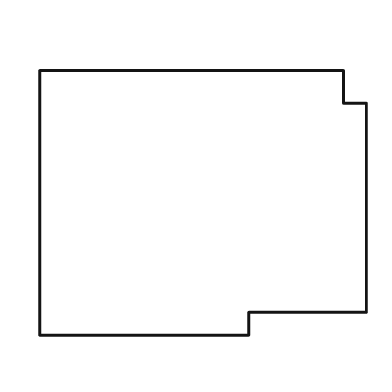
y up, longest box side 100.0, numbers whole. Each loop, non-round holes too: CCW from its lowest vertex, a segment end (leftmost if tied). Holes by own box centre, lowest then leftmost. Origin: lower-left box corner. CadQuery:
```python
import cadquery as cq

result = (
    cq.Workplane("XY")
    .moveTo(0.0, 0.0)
    .lineTo(64.0, 0.0)
    .lineTo(64.0, 7.0)
    .lineTo(100.0, 7.0)
    .lineTo(100.0, 71.0)
    .lineTo(93.0, 71.0)
    .lineTo(93.0, 81.0)
    .lineTo(0.0, 81.0)
    .close()
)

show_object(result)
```